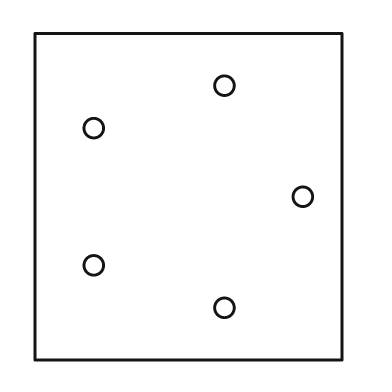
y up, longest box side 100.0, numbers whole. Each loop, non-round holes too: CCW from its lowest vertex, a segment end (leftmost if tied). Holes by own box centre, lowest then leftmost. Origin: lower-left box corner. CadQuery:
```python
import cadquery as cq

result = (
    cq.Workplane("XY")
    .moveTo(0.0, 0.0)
    .lineTo(94.0, 0.0)
    .lineTo(94.0, 100.0)
    .lineTo(0.0, 100.0)
    .close()
    .moveTo(58.0, 16.0)
    .circle(3.0)
    .moveTo(18.0, 29.0)
    .circle(3.0)
    .moveTo(82.0, 50.0)
    .circle(3.0)
    .moveTo(18.0, 71.0)
    .circle(3.0)
    .moveTo(58.0, 84.0)
    .circle(3.0)
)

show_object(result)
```